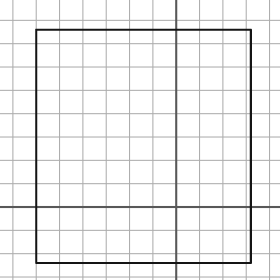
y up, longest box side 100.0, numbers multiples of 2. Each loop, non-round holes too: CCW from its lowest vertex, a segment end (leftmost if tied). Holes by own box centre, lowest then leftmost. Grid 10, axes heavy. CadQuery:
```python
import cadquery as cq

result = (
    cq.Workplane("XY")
    .moveTo(-60.0, -24.0)
    .lineTo(32.0, -24.0)
    .lineTo(32.0, 76.0)
    .lineTo(-60.0, 76.0)
    .close()
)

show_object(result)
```